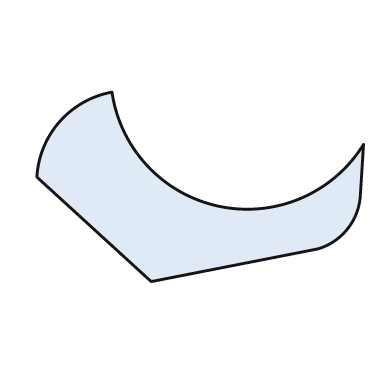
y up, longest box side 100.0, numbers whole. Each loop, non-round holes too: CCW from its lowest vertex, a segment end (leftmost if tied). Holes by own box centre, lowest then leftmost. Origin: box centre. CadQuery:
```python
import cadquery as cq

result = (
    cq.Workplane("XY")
    .moveTo(-15.0, -29.0)
    .lineTo(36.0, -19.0)
    .threePointArc((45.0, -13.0), (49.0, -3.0))
    .lineTo(50.0, 13.0)
    .threePointArc((6.0, -6.0), (-27.0, 29.0))
    .threePointArc((-43.0, 20.0), (-50.0, 3.0))
    .close()
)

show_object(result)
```